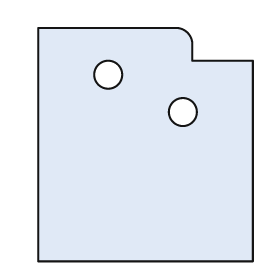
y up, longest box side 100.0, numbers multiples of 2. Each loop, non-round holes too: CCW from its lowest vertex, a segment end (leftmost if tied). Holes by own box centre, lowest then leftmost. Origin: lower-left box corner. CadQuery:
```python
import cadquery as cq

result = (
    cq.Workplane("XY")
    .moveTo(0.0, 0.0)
    .lineTo(92.0, 0.0)
    .lineTo(92.0, 86.0)
    .lineTo(66.0, 86.0)
    .lineTo(66.0, 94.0)
    .threePointArc((64.0, 98.0), (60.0, 100.0))
    .lineTo(0.0, 100.0)
    .close()
    .moveTo(62.0, 64.0)
    .circle(6.0)
    .moveTo(30.0, 80.0)
    .circle(6.0)
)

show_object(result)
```